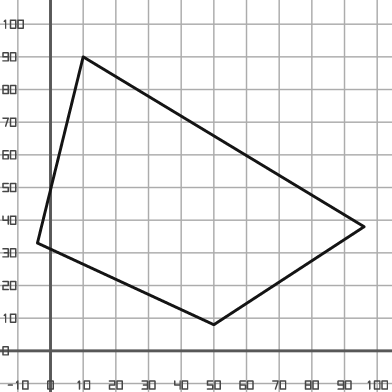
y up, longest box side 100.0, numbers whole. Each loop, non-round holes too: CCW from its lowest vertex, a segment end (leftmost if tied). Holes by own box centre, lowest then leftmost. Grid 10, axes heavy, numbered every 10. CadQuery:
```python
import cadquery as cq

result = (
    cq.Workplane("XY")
    .moveTo(50.0, 8.0)
    .lineTo(96.0, 38.0)
    .lineTo(10.0, 90.0)
    .lineTo(-4.0, 33.0)
    .close()
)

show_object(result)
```